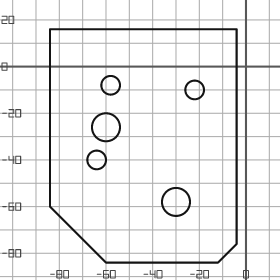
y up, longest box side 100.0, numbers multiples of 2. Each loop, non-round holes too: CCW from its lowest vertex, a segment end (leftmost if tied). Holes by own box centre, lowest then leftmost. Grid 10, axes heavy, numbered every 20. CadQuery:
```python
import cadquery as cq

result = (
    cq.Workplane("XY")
    .moveTo(-60.0, -84.0)
    .lineTo(-12.0, -84.0)
    .lineTo(-4.0, -76.0)
    .lineTo(-4.0, 16.0)
    .lineTo(-84.0, 16.0)
    .lineTo(-84.0, -60.0)
    .close()
    .moveTo(-30.0, -58.0)
    .circle(6.0)
    .moveTo(-64.0, -40.0)
    .circle(4.0)
    .moveTo(-60.0, -26.0)
    .circle(6.0)
    .moveTo(-22.0, -10.0)
    .circle(4.0)
    .moveTo(-58.0, -8.0)
    .circle(4.0)
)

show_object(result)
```